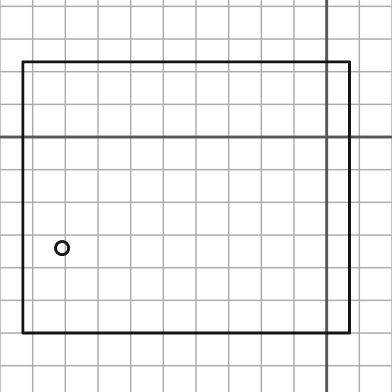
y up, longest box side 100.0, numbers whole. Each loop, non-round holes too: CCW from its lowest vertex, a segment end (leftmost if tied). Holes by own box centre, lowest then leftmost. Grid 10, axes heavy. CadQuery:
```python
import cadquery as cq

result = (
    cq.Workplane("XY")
    .moveTo(-93.0, -60.0)
    .lineTo(7.0, -60.0)
    .lineTo(7.0, 23.0)
    .lineTo(-93.0, 23.0)
    .close()
    .moveTo(-81.0, -34.0)
    .circle(2.0)
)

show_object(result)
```